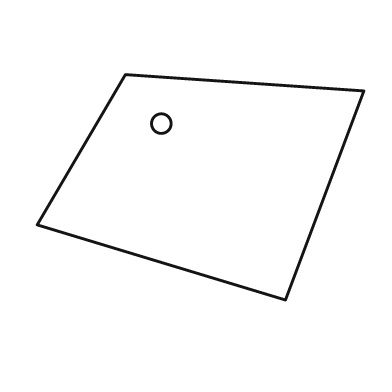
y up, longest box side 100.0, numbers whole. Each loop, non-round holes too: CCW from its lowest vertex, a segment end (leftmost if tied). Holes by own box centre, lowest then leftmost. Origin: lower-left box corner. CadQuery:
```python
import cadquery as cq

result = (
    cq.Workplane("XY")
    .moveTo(76.0, 0.0)
    .lineTo(100.0, 64.0)
    .lineTo(27.0, 69.0)
    .lineTo(0.0, 23.0)
    .close()
    .moveTo(38.0, 54.0)
    .circle(3.0)
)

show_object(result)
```